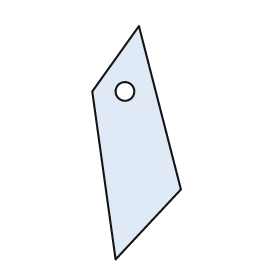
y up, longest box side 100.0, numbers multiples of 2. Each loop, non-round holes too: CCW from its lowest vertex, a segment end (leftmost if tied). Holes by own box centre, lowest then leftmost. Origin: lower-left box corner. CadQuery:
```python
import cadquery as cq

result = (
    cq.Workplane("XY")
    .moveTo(10.0, 0.0)
    .lineTo(38.0, 30.0)
    .lineTo(20.0, 100.0)
    .lineTo(0.0, 72.0)
    .close()
    .moveTo(14.0, 72.0)
    .circle(4.0)
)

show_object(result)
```